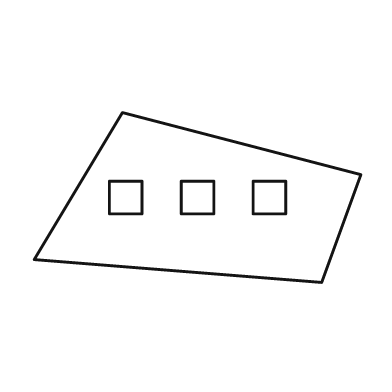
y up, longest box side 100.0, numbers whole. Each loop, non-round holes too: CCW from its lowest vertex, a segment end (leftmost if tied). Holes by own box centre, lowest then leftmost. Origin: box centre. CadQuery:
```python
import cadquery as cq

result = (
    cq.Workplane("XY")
    .moveTo(38.0, -26.0)
    .lineTo(50.0, 7.0)
    .lineTo(-23.0, 26.0)
    .lineTo(-50.0, -19.0)
    .close()
    .moveTo(-27.0, -5.0)
    .lineTo(-17.0, -5.0)
    .lineTo(-17.0, 5.0)
    .lineTo(-27.0, 5.0)
    .close()
    .moveTo(-5.0, -5.0)
    .lineTo(5.0, -5.0)
    .lineTo(5.0, 5.0)
    .lineTo(-5.0, 5.0)
    .close()
    .moveTo(17.0, -5.0)
    .lineTo(27.0, -5.0)
    .lineTo(27.0, 5.0)
    .lineTo(17.0, 5.0)
    .close()
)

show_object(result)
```